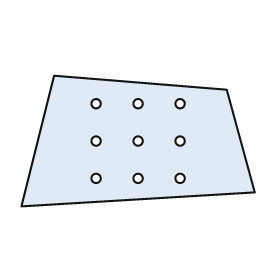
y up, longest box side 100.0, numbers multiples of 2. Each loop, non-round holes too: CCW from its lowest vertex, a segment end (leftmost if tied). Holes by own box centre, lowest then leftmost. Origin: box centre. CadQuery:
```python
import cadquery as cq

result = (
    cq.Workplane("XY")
    .moveTo(-50.0, -28.0)
    .lineTo(50.0, -22.0)
    .lineTo(38.0, 22.0)
    .lineTo(-36.0, 28.0)
    .close()
    .moveTo(-18.0, -16.0)
    .circle(2.0)
    .moveTo(0.0, -16.0)
    .circle(2.0)
    .moveTo(18.0, -16.0)
    .circle(2.0)
    .moveTo(-18.0, 0.0)
    .circle(2.0)
    .moveTo(0.0, 0.0)
    .circle(2.0)
    .moveTo(18.0, 0.0)
    .circle(2.0)
    .moveTo(-18.0, 16.0)
    .circle(2.0)
    .moveTo(0.0, 16.0)
    .circle(2.0)
    .moveTo(18.0, 16.0)
    .circle(2.0)
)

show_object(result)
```